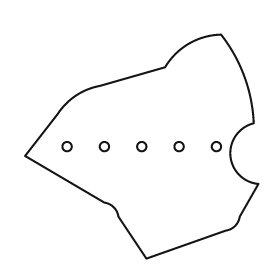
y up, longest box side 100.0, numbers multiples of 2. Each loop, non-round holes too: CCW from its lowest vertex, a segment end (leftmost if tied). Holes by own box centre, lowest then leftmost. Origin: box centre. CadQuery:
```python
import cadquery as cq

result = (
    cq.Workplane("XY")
    .moveTo(2.0, -48.0)
    .lineTo(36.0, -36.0)
    .threePointArc((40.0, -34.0), (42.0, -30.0))
    .lineTo(50.0, -16.0)
    .threePointArc((38.0, -4.0), (48.0, 10.0))
    .threePointArc((44.0, 30.0), (34.0, 48.0))
    .threePointArc((20.0, 44.0), (10.0, 34.0))
    .lineTo(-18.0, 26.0)
    .threePointArc((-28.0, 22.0), (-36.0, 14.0))
    .lineTo(-50.0, -4.0)
    .lineTo(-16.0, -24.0)
    .threePointArc((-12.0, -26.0), (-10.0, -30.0))
    .close()
    .moveTo(-32.0, 0.0)
    .circle(2.0)
    .moveTo(-16.0, 0.0)
    .circle(2.0)
    .moveTo(0.0, 0.0)
    .circle(2.0)
    .moveTo(16.0, 0.0)
    .circle(2.0)
    .moveTo(32.0, 0.0)
    .circle(2.0)
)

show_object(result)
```